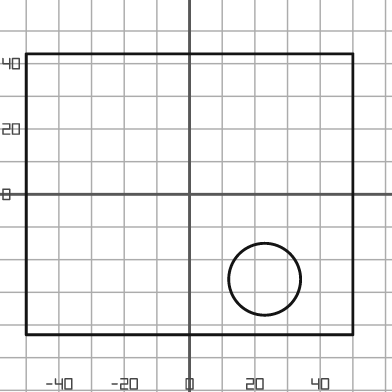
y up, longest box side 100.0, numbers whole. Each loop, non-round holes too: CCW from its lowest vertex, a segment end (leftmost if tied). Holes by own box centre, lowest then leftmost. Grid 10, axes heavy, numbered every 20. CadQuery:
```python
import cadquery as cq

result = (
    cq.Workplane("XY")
    .moveTo(-50.0, -43.0)
    .lineTo(50.0, -43.0)
    .lineTo(50.0, 43.0)
    .lineTo(-50.0, 43.0)
    .close()
    .moveTo(23.0, -26.0)
    .circle(11.0)
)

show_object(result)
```